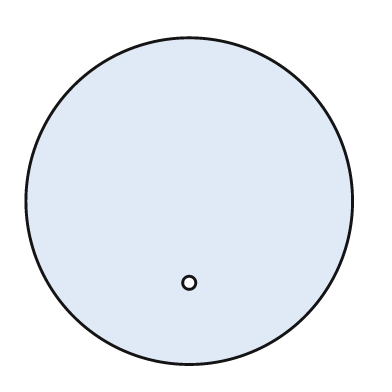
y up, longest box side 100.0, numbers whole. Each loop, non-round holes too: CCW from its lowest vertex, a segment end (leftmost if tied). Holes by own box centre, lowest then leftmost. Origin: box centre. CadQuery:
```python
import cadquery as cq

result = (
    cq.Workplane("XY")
    .moveTo(0.0, 0.0)
    .circle(50.0)
    .moveTo(0.0, -25.0)
    .circle(2.0)
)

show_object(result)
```